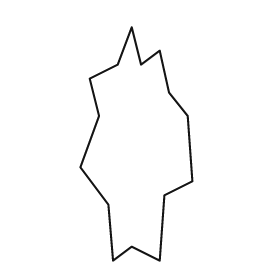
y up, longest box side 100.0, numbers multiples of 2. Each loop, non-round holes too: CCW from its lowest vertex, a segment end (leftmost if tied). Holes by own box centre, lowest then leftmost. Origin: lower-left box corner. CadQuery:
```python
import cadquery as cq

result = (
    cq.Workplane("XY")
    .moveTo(14.0, 0.0)
    .lineTo(22.0, 6.0)
    .lineTo(34.0, 0.0)
    .lineTo(36.0, 28.0)
    .lineTo(48.0, 34.0)
    .lineTo(46.0, 62.0)
    .lineTo(38.0, 72.0)
    .lineTo(34.0, 90.0)
    .lineTo(26.0, 84.0)
    .lineTo(22.0, 100.0)
    .lineTo(16.0, 84.0)
    .lineTo(4.0, 78.0)
    .lineTo(8.0, 62.0)
    .lineTo(0.0, 40.0)
    .lineTo(12.0, 24.0)
    .close()
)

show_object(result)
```